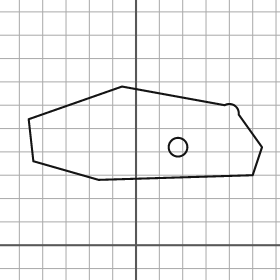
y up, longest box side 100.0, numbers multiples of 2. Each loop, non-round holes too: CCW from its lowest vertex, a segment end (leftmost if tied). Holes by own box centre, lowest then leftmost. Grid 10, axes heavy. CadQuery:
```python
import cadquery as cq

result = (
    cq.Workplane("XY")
    .moveTo(-16.0, 28.0)
    .lineTo(50.0, 30.0)
    .lineTo(54.0, 42.0)
    .lineTo(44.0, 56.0)
    .threePointArc((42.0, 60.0), (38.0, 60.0))
    .lineTo(-6.0, 68.0)
    .lineTo(-46.0, 54.0)
    .lineTo(-44.0, 36.0)
    .close()
    .moveTo(18.0, 42.0)
    .circle(4.0)
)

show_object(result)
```